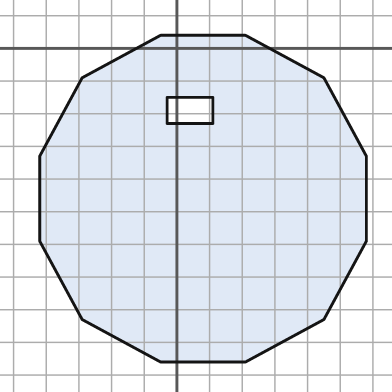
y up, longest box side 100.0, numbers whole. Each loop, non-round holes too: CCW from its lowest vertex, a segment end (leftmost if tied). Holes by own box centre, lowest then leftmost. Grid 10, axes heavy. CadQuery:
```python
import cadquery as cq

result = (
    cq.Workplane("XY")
    .moveTo(-5.0, -96.0)
    .lineTo(21.0, -96.0)
    .lineTo(45.0, -83.0)
    .lineTo(58.0, -59.0)
    .lineTo(58.0, -33.0)
    .lineTo(45.0, -9.0)
    .lineTo(21.0, 4.0)
    .lineTo(-5.0, 4.0)
    .lineTo(-29.0, -9.0)
    .lineTo(-42.0, -33.0)
    .lineTo(-42.0, -59.0)
    .lineTo(-29.0, -83.0)
    .close()
    .moveTo(-3.0, -23.0)
    .lineTo(11.0, -23.0)
    .lineTo(11.0, -15.0)
    .lineTo(-3.0, -15.0)
    .close()
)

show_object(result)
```